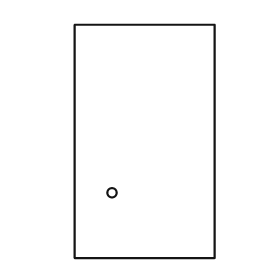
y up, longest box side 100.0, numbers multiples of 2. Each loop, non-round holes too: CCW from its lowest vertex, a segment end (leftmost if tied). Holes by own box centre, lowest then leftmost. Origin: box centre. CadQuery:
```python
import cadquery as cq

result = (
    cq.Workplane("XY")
    .moveTo(-30.0, -50.0)
    .lineTo(30.0, -50.0)
    .lineTo(30.0, 50.0)
    .lineTo(-30.0, 50.0)
    .close()
    .moveTo(-14.0, -22.0)
    .circle(2.0)
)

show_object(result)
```